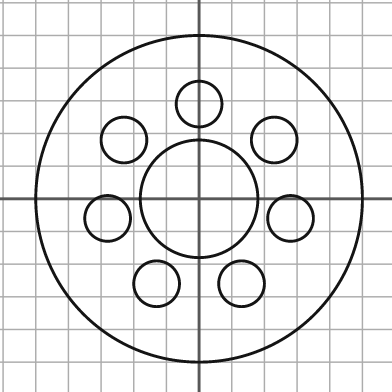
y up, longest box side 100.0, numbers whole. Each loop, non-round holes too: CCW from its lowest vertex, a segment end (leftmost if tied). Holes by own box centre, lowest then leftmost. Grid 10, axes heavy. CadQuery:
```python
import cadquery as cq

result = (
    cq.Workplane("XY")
    .moveTo(0.0, 0.0)
    .circle(50.0)
    .moveTo(-13.0, -26.0)
    .circle(7.0)
    .moveTo(13.0, -26.0)
    .circle(7.0)
    .moveTo(-28.0, -6.0)
    .circle(7.0)
    .moveTo(28.0, -6.0)
    .circle(7.0)
    .moveTo(0.0, 0.0)
    .circle(18.0)
    .moveTo(-23.0, 18.0)
    .circle(7.0)
    .moveTo(23.0, 18.0)
    .circle(7.0)
    .moveTo(0.0, 29.0)
    .circle(7.0)
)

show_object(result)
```